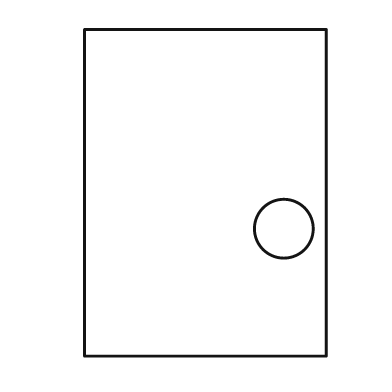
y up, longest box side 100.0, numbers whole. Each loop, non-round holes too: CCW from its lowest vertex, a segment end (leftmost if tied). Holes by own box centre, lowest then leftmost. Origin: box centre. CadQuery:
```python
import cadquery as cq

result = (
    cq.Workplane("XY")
    .moveTo(-37.0, -50.0)
    .lineTo(37.0, -50.0)
    .lineTo(37.0, 50.0)
    .lineTo(-37.0, 50.0)
    .close()
    .moveTo(24.0, -11.0)
    .circle(9.0)
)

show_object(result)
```